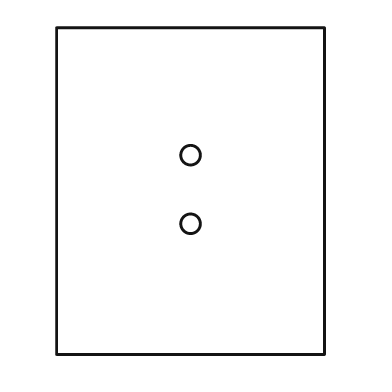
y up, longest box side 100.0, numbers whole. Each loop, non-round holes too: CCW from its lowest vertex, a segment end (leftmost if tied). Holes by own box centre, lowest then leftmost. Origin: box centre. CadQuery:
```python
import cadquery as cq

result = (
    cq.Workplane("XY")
    .moveTo(-41.0, -50.0)
    .lineTo(41.0, -50.0)
    .lineTo(41.0, 50.0)
    .lineTo(-41.0, 50.0)
    .close()
    .moveTo(0.0, -10.0)
    .circle(3.0)
    .moveTo(0.0, 11.0)
    .circle(3.0)
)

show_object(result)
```